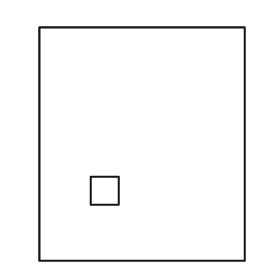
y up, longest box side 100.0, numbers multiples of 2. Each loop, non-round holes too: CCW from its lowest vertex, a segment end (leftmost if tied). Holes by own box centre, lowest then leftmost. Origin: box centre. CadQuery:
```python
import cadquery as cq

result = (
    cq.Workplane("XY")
    .moveTo(-44.0, -50.0)
    .lineTo(44.0, -50.0)
    .lineTo(44.0, 50.0)
    .lineTo(-44.0, 50.0)
    .close()
    .moveTo(-22.0, -26.0)
    .lineTo(-10.0, -26.0)
    .lineTo(-10.0, -14.0)
    .lineTo(-22.0, -14.0)
    .close()
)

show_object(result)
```